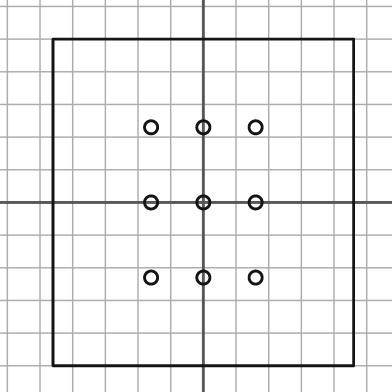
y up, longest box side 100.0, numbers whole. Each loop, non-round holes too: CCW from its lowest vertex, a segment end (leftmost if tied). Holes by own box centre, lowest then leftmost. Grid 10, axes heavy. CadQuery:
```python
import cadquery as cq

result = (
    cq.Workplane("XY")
    .moveTo(-46.0, -50.0)
    .lineTo(46.0, -50.0)
    .lineTo(46.0, 50.0)
    .lineTo(-46.0, 50.0)
    .close()
    .moveTo(-16.0, -23.0)
    .circle(2.0)
    .moveTo(0.0, -23.0)
    .circle(2.0)
    .moveTo(16.0, -23.0)
    .circle(2.0)
    .moveTo(-16.0, 0.0)
    .circle(2.0)
    .moveTo(0.0, 0.0)
    .circle(2.0)
    .moveTo(16.0, 0.0)
    .circle(2.0)
    .moveTo(-16.0, 23.0)
    .circle(2.0)
    .moveTo(0.0, 23.0)
    .circle(2.0)
    .moveTo(16.0, 23.0)
    .circle(2.0)
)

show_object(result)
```